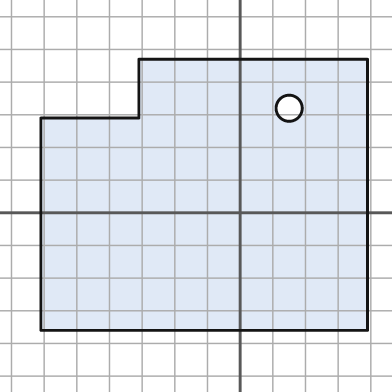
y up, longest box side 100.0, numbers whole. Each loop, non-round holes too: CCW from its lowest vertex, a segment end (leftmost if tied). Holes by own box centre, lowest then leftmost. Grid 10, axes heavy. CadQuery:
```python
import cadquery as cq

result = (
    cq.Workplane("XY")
    .moveTo(-61.0, -36.0)
    .lineTo(39.0, -36.0)
    .lineTo(39.0, 47.0)
    .lineTo(-31.0, 47.0)
    .lineTo(-31.0, 29.0)
    .lineTo(-61.0, 29.0)
    .close()
    .moveTo(15.0, 32.0)
    .circle(4.0)
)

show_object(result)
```